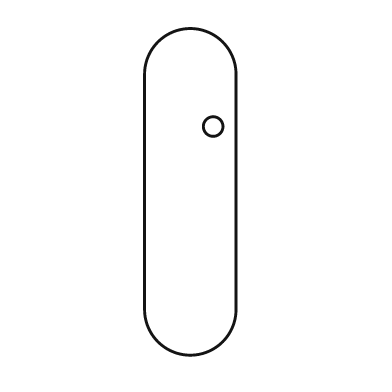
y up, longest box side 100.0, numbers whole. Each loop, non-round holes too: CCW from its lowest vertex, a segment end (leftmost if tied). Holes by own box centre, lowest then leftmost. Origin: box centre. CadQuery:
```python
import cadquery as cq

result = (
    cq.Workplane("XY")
    .moveTo(-14.0, -36.0)
    .threePointArc((0.0, -50.0), (14.0, -36.0))
    .lineTo(14.0, 36.0)
    .threePointArc((0.0, 50.0), (-14.0, 36.0))
    .close()
    .moveTo(7.0, 20.0)
    .circle(3.0)
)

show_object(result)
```